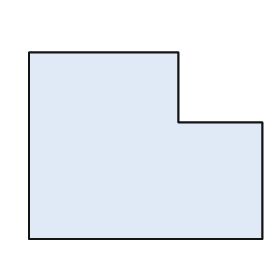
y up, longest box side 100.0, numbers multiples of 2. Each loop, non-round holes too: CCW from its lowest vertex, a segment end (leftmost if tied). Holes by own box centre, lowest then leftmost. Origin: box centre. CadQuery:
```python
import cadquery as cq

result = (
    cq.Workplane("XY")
    .moveTo(-50.0, -40.0)
    .lineTo(50.0, -40.0)
    .lineTo(50.0, 10.0)
    .lineTo(14.0, 10.0)
    .lineTo(14.0, 40.0)
    .lineTo(-50.0, 40.0)
    .close()
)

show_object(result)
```